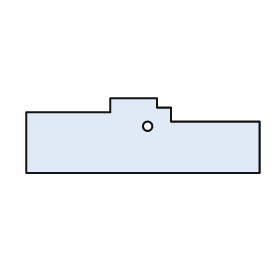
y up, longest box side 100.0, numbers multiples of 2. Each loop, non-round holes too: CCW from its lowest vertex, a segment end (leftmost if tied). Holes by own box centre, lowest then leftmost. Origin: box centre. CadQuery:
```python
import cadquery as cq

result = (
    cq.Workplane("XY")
    .moveTo(-50.0, -16.0)
    .lineTo(50.0, -16.0)
    .lineTo(50.0, 6.0)
    .lineTo(12.0, 6.0)
    .lineTo(12.0, 12.0)
    .lineTo(6.0, 12.0)
    .lineTo(6.0, 16.0)
    .lineTo(-14.0, 16.0)
    .lineTo(-14.0, 10.0)
    .lineTo(-50.0, 10.0)
    .close()
    .moveTo(2.0, 4.0)
    .circle(2.0)
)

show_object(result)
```